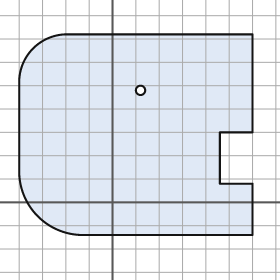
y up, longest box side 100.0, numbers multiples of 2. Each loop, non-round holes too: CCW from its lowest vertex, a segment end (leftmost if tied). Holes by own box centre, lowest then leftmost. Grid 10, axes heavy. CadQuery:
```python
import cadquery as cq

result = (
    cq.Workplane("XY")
    .moveTo(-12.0, -14.0)
    .lineTo(60.0, -14.0)
    .lineTo(60.0, 8.0)
    .lineTo(46.0, 8.0)
    .lineTo(46.0, 30.0)
    .lineTo(60.0, 30.0)
    .lineTo(60.0, 72.0)
    .lineTo(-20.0, 72.0)
    .threePointArc((-34.0, 66.0), (-40.0, 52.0))
    .lineTo(-40.0, 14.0)
    .threePointArc((-32.0, -6.0), (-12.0, -14.0))
    .close()
    .moveTo(12.0, 48.0)
    .circle(2.0)
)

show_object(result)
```